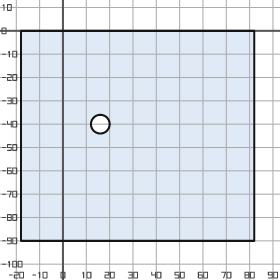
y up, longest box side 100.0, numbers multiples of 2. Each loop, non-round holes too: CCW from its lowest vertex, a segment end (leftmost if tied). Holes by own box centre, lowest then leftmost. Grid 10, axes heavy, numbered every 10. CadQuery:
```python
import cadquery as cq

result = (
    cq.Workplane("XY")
    .moveTo(-18.0, -90.0)
    .lineTo(82.0, -90.0)
    .lineTo(82.0, 0.0)
    .lineTo(-18.0, 0.0)
    .close()
    .moveTo(16.0, -40.0)
    .circle(4.0)
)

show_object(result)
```